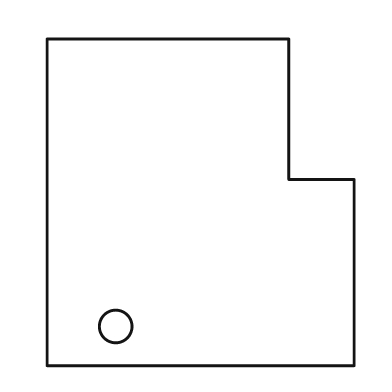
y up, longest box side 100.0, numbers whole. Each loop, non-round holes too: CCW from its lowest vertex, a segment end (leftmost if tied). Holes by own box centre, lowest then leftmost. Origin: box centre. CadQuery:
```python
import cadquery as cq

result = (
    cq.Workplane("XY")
    .moveTo(-47.0, -50.0)
    .lineTo(47.0, -50.0)
    .lineTo(47.0, 7.0)
    .lineTo(27.0, 7.0)
    .lineTo(27.0, 50.0)
    .lineTo(-47.0, 50.0)
    .close()
    .moveTo(-26.0, -38.0)
    .circle(5.0)
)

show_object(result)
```